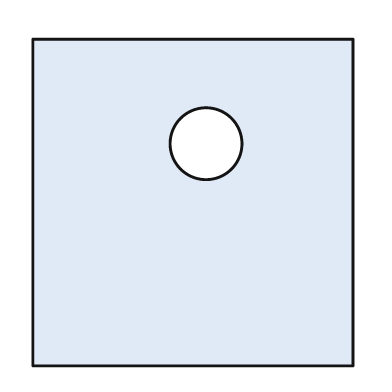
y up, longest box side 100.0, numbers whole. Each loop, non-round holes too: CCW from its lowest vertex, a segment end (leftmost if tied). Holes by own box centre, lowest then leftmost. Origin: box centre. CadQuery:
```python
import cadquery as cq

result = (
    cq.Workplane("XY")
    .moveTo(-49.0, -50.0)
    .lineTo(49.0, -50.0)
    .lineTo(49.0, 50.0)
    .lineTo(-49.0, 50.0)
    .close()
    .moveTo(4.0, 18.0)
    .circle(11.0)
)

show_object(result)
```